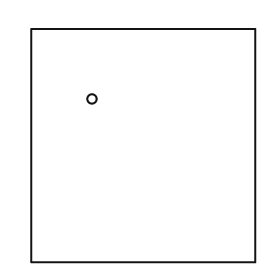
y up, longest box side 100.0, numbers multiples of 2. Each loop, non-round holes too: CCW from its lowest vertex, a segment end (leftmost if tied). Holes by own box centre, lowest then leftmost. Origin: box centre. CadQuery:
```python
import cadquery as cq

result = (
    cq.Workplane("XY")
    .moveTo(-48.0, -50.0)
    .lineTo(48.0, -50.0)
    .lineTo(48.0, 50.0)
    .lineTo(-48.0, 50.0)
    .close()
    .moveTo(-22.0, 20.0)
    .circle(2.0)
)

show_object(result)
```